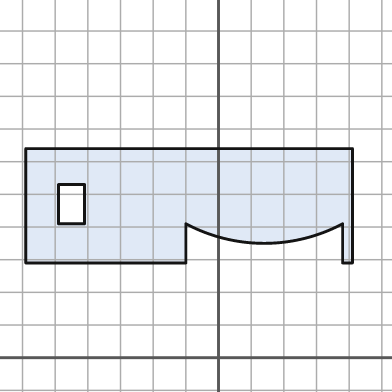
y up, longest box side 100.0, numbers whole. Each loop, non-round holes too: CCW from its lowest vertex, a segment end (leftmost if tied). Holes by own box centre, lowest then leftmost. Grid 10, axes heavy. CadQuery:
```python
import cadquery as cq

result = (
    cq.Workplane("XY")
    .moveTo(-59.0, 29.0)
    .lineTo(-10.0, 29.0)
    .lineTo(-10.0, 41.0)
    .threePointArc((14.0, 35.0), (38.0, 41.0))
    .lineTo(38.0, 29.0)
    .lineTo(41.0, 29.0)
    .lineTo(41.0, 64.0)
    .lineTo(-59.0, 64.0)
    .close()
    .moveTo(-49.0, 41.0)
    .lineTo(-41.0, 41.0)
    .lineTo(-41.0, 53.0)
    .lineTo(-49.0, 53.0)
    .close()
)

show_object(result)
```